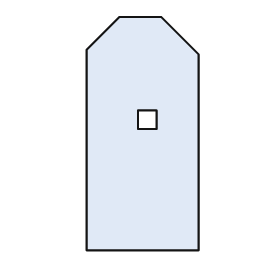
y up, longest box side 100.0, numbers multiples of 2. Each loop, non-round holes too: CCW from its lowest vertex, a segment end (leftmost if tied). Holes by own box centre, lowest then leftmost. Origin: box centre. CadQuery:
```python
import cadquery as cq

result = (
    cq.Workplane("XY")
    .moveTo(-24.0, -50.0)
    .lineTo(24.0, -50.0)
    .lineTo(24.0, 34.0)
    .lineTo(8.0, 50.0)
    .lineTo(-10.0, 50.0)
    .lineTo(-24.0, 36.0)
    .close()
    .moveTo(-2.0, 2.0)
    .lineTo(6.0, 2.0)
    .lineTo(6.0, 10.0)
    .lineTo(-2.0, 10.0)
    .close()
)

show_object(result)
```